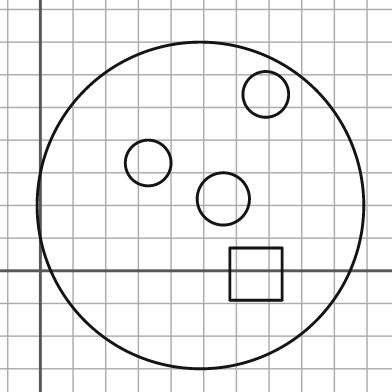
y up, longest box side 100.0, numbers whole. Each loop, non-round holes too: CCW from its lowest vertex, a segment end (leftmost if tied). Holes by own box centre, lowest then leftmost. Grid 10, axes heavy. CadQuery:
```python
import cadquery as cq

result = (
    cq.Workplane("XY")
    .moveTo(49.0, 20.0)
    .circle(50.0)
    .moveTo(58.0, -9.0)
    .lineTo(74.0, -9.0)
    .lineTo(74.0, 7.0)
    .lineTo(58.0, 7.0)
    .close()
    .moveTo(56.0, 22.0)
    .circle(8.0)
    .moveTo(33.0, 33.0)
    .circle(7.0)
    .moveTo(69.0, 54.0)
    .circle(7.0)
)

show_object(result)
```